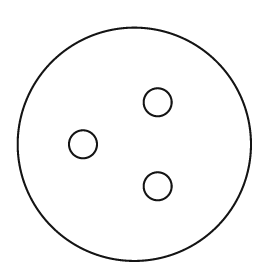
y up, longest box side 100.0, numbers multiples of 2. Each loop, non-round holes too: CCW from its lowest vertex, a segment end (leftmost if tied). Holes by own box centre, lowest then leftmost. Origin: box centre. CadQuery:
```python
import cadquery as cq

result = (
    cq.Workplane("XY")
    .moveTo(0.0, 0.0)
    .circle(50.0)
    .moveTo(10.0, -18.0)
    .circle(6.0)
    .moveTo(-22.0, 0.0)
    .circle(6.0)
    .moveTo(10.0, 18.0)
    .circle(6.0)
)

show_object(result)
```